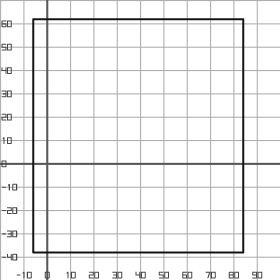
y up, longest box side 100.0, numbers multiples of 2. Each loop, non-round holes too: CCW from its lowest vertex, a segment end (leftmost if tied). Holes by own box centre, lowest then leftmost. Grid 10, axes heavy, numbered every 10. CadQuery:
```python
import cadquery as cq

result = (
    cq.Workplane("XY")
    .moveTo(-6.0, -38.0)
    .lineTo(84.0, -38.0)
    .lineTo(84.0, 62.0)
    .lineTo(-6.0, 62.0)
    .close()
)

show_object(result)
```